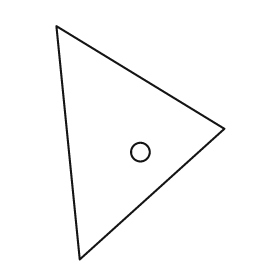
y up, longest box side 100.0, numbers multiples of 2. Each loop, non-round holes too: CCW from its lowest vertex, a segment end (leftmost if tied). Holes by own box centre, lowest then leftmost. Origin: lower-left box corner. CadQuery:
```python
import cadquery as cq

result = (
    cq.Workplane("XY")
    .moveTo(10.0, 0.0)
    .lineTo(72.0, 56.0)
    .lineTo(0.0, 100.0)
    .close()
    .moveTo(36.0, 46.0)
    .circle(4.0)
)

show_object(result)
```